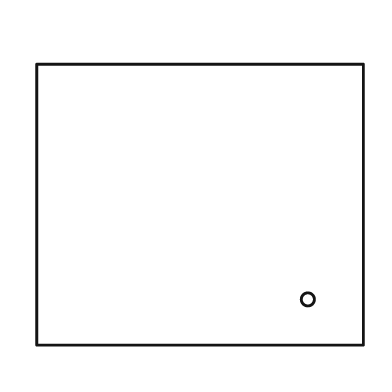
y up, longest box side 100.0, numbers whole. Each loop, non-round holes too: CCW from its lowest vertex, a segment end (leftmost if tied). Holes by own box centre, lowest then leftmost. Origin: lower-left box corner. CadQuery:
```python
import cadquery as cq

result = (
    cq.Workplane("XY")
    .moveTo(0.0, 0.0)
    .lineTo(100.0, 0.0)
    .lineTo(100.0, 86.0)
    .lineTo(0.0, 86.0)
    .close()
    .moveTo(83.0, 14.0)
    .circle(2.0)
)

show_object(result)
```